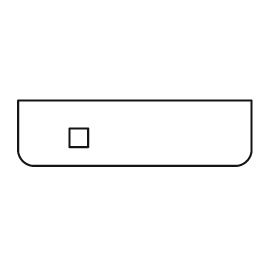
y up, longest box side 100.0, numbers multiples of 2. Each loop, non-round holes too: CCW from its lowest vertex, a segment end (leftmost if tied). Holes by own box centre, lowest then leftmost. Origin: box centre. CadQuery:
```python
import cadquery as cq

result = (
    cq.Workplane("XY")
    .moveTo(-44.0, -14.0)
    .lineTo(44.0, -14.0)
    .threePointArc((48.0, -12.0), (50.0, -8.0))
    .lineTo(50.0, 14.0)
    .lineTo(-50.0, 14.0)
    .lineTo(-50.0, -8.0)
    .threePointArc((-48.0, -12.0), (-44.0, -14.0))
    .close()
    .moveTo(-28.0, -6.0)
    .lineTo(-20.0, -6.0)
    .lineTo(-20.0, 2.0)
    .lineTo(-28.0, 2.0)
    .close()
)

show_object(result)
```